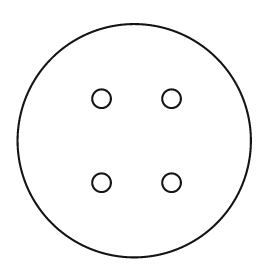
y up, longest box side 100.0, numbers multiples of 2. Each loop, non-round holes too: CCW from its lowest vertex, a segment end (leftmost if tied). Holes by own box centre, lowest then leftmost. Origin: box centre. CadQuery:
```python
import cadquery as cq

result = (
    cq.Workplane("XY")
    .moveTo(0.0, 0.0)
    .circle(50.0)
    .moveTo(-14.0, -18.0)
    .circle(4.0)
    .moveTo(16.0, -18.0)
    .circle(4.0)
    .moveTo(-14.0, 18.0)
    .circle(4.0)
    .moveTo(16.0, 18.0)
    .circle(4.0)
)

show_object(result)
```